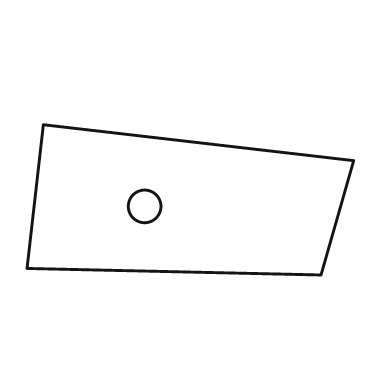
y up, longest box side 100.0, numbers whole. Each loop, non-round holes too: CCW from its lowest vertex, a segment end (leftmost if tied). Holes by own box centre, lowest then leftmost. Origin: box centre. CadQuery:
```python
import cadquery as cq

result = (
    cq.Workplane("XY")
    .moveTo(40.0, -23.0)
    .lineTo(50.0, 12.0)
    .lineTo(-45.0, 23.0)
    .lineTo(-50.0, -21.0)
    .close()
    .moveTo(-14.0, -2.0)
    .circle(5.0)
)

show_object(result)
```